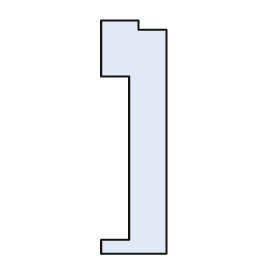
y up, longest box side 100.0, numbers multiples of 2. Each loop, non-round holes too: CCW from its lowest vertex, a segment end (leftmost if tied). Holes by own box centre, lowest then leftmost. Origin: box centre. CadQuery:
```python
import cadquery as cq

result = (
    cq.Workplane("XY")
    .moveTo(-14.0, -50.0)
    .lineTo(14.0, -50.0)
    .lineTo(14.0, 46.0)
    .lineTo(2.0, 46.0)
    .lineTo(2.0, 50.0)
    .lineTo(-14.0, 50.0)
    .lineTo(-14.0, 26.0)
    .lineTo(-2.0, 26.0)
    .lineTo(-2.0, -44.0)
    .lineTo(-14.0, -44.0)
    .close()
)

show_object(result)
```